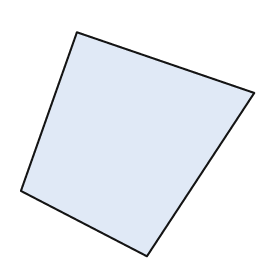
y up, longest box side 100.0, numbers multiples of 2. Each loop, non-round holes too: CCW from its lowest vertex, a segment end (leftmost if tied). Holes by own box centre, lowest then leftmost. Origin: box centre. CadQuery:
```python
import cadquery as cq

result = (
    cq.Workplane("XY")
    .moveTo(4.0, -48.0)
    .lineTo(50.0, 22.0)
    .lineTo(-26.0, 48.0)
    .lineTo(-50.0, -20.0)
    .close()
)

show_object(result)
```